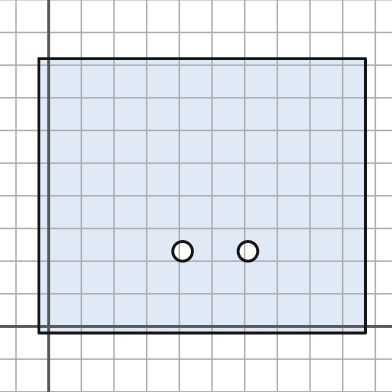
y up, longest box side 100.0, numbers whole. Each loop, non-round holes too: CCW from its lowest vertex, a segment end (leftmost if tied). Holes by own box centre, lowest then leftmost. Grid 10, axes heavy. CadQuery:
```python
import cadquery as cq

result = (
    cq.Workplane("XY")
    .moveTo(-3.0, -2.0)
    .lineTo(97.0, -2.0)
    .lineTo(97.0, 82.0)
    .lineTo(-3.0, 82.0)
    .close()
    .moveTo(41.0, 23.0)
    .circle(3.0)
    .moveTo(61.0, 23.0)
    .circle(3.0)
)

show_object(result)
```